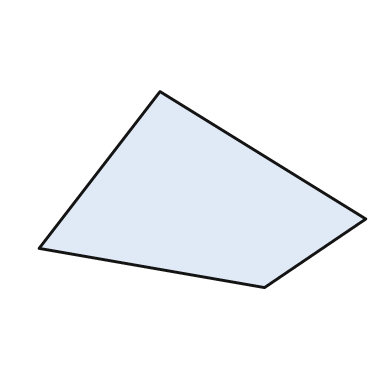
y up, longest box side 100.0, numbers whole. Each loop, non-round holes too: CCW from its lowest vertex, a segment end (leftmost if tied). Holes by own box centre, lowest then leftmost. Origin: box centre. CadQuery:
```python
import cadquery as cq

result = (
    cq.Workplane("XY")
    .moveTo(19.0, -30.0)
    .lineTo(50.0, -9.0)
    .lineTo(-13.0, 30.0)
    .lineTo(-50.0, -18.0)
    .close()
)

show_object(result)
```